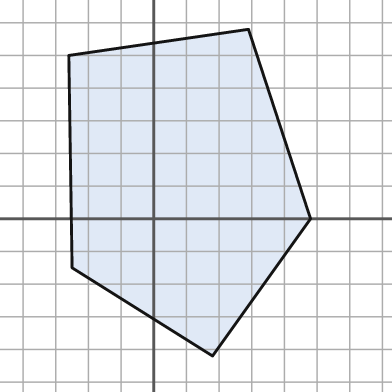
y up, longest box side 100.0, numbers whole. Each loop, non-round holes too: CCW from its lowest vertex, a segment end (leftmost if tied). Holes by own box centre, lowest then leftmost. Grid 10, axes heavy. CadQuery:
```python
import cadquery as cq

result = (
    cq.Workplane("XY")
    .moveTo(18.0, -42.0)
    .lineTo(48.0, 0.0)
    .lineTo(29.0, 58.0)
    .lineTo(-26.0, 50.0)
    .lineTo(-25.0, -15.0)
    .close()
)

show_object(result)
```